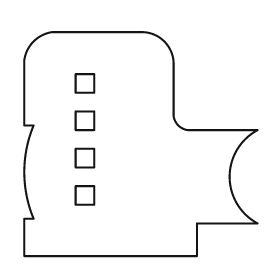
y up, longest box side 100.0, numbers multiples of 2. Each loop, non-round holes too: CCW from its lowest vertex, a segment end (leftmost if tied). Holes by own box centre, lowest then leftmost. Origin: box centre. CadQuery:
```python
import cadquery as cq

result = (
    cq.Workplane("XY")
    .moveTo(-50.0, -48.0)
    .lineTo(24.0, -48.0)
    .lineTo(24.0, -34.0)
    .lineTo(50.0, -34.0)
    .threePointArc((38.0, -14.0), (50.0, 6.0))
    .lineTo(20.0, 6.0)
    .threePointArc((16.0, 8.0), (14.0, 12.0))
    .lineTo(14.0, 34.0)
    .threePointArc((10.0, 44.0), (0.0, 48.0))
    .lineTo(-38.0, 48.0)
    .threePointArc((-46.0, 44.0), (-50.0, 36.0))
    .lineTo(-50.0, 8.0)
    .lineTo(-46.0, 8.0)
    .threePointArc((-50.0, -12.0), (-46.0, -32.0))
    .lineTo(-50.0, -32.0)
    .close()
    .moveTo(-28.0, -26.0)
    .lineTo(-20.0, -26.0)
    .lineTo(-20.0, -18.0)
    .lineTo(-28.0, -18.0)
    .close()
    .moveTo(-28.0, -10.0)
    .lineTo(-20.0, -10.0)
    .lineTo(-20.0, -2.0)
    .lineTo(-28.0, -2.0)
    .close()
    .moveTo(-28.0, 6.0)
    .lineTo(-20.0, 6.0)
    .lineTo(-20.0, 14.0)
    .lineTo(-28.0, 14.0)
    .close()
    .moveTo(-28.0, 22.0)
    .lineTo(-20.0, 22.0)
    .lineTo(-20.0, 30.0)
    .lineTo(-28.0, 30.0)
    .close()
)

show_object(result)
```